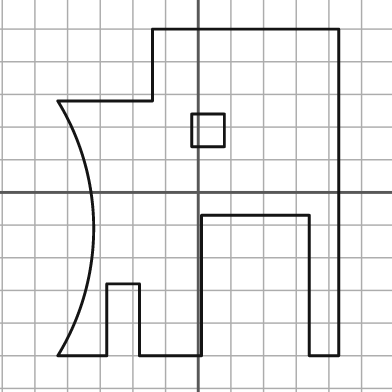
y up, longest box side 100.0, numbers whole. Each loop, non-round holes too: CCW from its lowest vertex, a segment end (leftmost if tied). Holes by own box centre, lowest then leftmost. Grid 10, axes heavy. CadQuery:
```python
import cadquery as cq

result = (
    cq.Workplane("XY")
    .moveTo(-43.0, -50.0)
    .lineTo(-28.0, -50.0)
    .lineTo(-28.0, -28.0)
    .lineTo(-18.0, -28.0)
    .lineTo(-18.0, -50.0)
    .lineTo(1.0, -50.0)
    .lineTo(1.0, -7.0)
    .lineTo(34.0, -7.0)
    .lineTo(34.0, -50.0)
    .lineTo(43.0, -50.0)
    .lineTo(43.0, 50.0)
    .lineTo(-14.0, 50.0)
    .lineTo(-14.0, 28.0)
    .lineTo(-43.0, 28.0)
    .threePointArc((-32.0, -11.0), (-43.0, -50.0))
    .close()
    .moveTo(-2.0, 14.0)
    .lineTo(8.0, 14.0)
    .lineTo(8.0, 24.0)
    .lineTo(-2.0, 24.0)
    .close()
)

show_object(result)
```